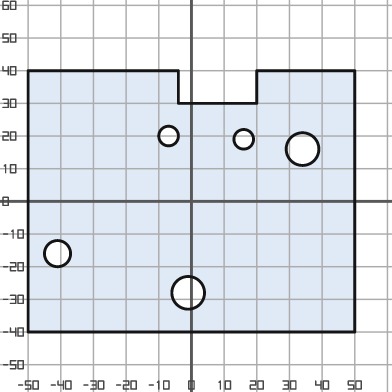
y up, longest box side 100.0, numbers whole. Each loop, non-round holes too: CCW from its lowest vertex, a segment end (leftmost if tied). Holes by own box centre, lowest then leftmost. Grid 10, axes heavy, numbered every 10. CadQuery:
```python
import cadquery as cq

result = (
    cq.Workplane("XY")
    .moveTo(-50.0, -40.0)
    .lineTo(50.0, -40.0)
    .lineTo(50.0, 40.0)
    .lineTo(20.0, 40.0)
    .lineTo(20.0, 30.0)
    .lineTo(-4.0, 30.0)
    .lineTo(-4.0, 40.0)
    .lineTo(-50.0, 40.0)
    .close()
    .moveTo(-1.0, -28.0)
    .circle(5.0)
    .moveTo(-41.0, -16.0)
    .circle(4.0)
    .moveTo(34.0, 16.0)
    .circle(5.0)
    .moveTo(16.0, 19.0)
    .circle(3.0)
    .moveTo(-7.0, 20.0)
    .circle(3.0)
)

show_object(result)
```